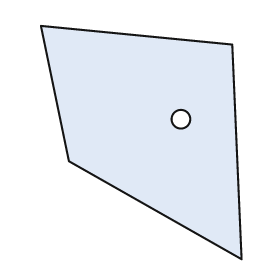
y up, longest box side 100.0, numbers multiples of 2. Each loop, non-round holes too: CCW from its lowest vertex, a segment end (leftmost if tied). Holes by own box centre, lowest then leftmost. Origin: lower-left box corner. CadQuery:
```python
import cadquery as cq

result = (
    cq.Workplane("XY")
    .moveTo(86.0, 0.0)
    .lineTo(82.0, 92.0)
    .lineTo(0.0, 100.0)
    .lineTo(12.0, 42.0)
    .close()
    .moveTo(60.0, 60.0)
    .circle(4.0)
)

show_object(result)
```